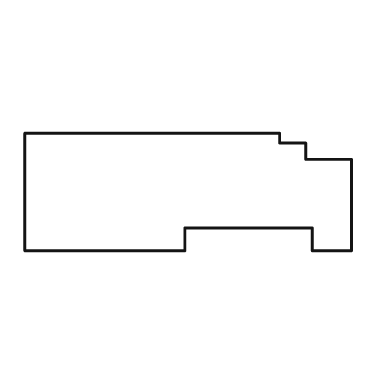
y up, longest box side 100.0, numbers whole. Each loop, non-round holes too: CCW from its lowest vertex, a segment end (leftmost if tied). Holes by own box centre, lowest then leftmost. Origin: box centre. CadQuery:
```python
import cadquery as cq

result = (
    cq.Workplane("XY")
    .moveTo(-50.0, -18.0)
    .lineTo(-1.0, -18.0)
    .lineTo(-1.0, -11.0)
    .lineTo(38.0, -11.0)
    .lineTo(38.0, -18.0)
    .lineTo(50.0, -18.0)
    .lineTo(50.0, 10.0)
    .lineTo(36.0, 10.0)
    .lineTo(36.0, 15.0)
    .lineTo(28.0, 15.0)
    .lineTo(28.0, 18.0)
    .lineTo(-50.0, 18.0)
    .close()
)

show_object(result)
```